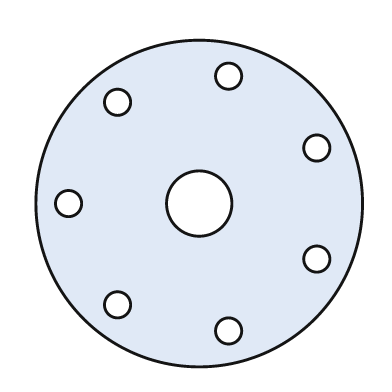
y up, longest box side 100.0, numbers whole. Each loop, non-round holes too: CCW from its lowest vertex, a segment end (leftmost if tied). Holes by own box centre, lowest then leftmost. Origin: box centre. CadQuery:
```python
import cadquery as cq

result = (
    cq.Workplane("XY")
    .moveTo(0.0, 0.0)
    .circle(50.0)
    .moveTo(9.0, -39.0)
    .circle(4.0)
    .moveTo(-25.0, -31.0)
    .circle(4.0)
    .moveTo(36.0, -17.0)
    .circle(4.0)
    .moveTo(-40.0, 0.0)
    .circle(4.0)
    .moveTo(0.0, 0.0)
    .circle(10.0)
    .moveTo(36.0, 17.0)
    .circle(4.0)
    .moveTo(-25.0, 31.0)
    .circle(4.0)
    .moveTo(9.0, 39.0)
    .circle(4.0)
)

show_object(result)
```